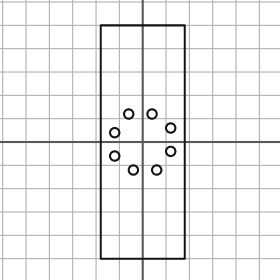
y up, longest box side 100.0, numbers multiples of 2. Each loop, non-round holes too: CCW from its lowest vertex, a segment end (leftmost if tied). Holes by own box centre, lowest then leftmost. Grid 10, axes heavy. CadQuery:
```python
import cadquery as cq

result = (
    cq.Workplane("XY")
    .moveTo(-18.0, -50.0)
    .lineTo(18.0, -50.0)
    .lineTo(18.0, 50.0)
    .lineTo(-18.0, 50.0)
    .close()
    .moveTo(-4.0, -12.0)
    .circle(2.0)
    .moveTo(6.0, -12.0)
    .circle(2.0)
    .moveTo(-12.0, -6.0)
    .circle(2.0)
    .moveTo(12.0, -4.0)
    .circle(2.0)
    .moveTo(-12.0, 4.0)
    .circle(2.0)
    .moveTo(12.0, 6.0)
    .circle(2.0)
    .moveTo(-6.0, 12.0)
    .circle(2.0)
    .moveTo(4.0, 12.0)
    .circle(2.0)
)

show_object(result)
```